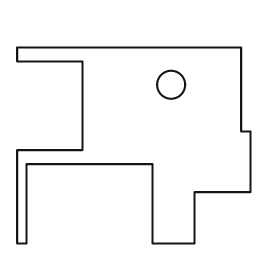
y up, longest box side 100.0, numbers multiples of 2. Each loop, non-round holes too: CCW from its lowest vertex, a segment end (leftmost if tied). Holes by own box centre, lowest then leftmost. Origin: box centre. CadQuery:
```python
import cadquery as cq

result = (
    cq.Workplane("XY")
    .moveTo(-50.0, -42.0)
    .lineTo(-46.0, -42.0)
    .lineTo(-46.0, -8.0)
    .lineTo(8.0, -8.0)
    .lineTo(8.0, -42.0)
    .lineTo(26.0, -42.0)
    .lineTo(26.0, -20.0)
    .lineTo(50.0, -20.0)
    .lineTo(50.0, 6.0)
    .lineTo(46.0, 6.0)
    .lineTo(46.0, 42.0)
    .lineTo(-50.0, 42.0)
    .lineTo(-50.0, 36.0)
    .lineTo(-22.0, 36.0)
    .lineTo(-22.0, -2.0)
    .lineTo(-50.0, -2.0)
    .close()
    .moveTo(16.0, 26.0)
    .circle(6.0)
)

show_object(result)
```